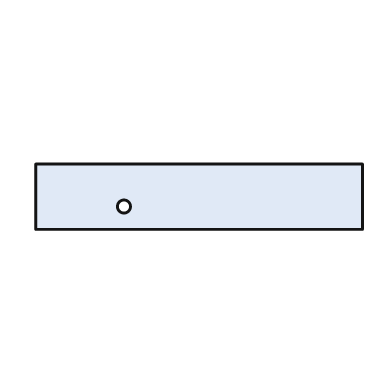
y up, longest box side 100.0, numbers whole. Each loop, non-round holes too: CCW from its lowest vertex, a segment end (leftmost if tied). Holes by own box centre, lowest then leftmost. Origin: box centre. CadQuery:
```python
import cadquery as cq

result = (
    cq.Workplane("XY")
    .moveTo(-50.0, -10.0)
    .lineTo(50.0, -10.0)
    .lineTo(50.0, 10.0)
    .lineTo(-50.0, 10.0)
    .close()
    .moveTo(-23.0, -3.0)
    .circle(2.0)
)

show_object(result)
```